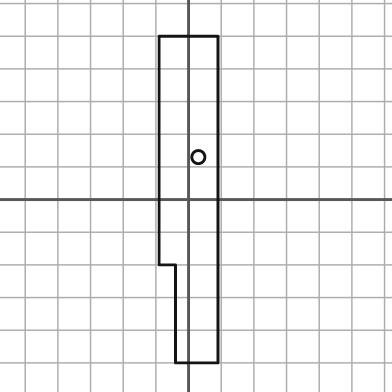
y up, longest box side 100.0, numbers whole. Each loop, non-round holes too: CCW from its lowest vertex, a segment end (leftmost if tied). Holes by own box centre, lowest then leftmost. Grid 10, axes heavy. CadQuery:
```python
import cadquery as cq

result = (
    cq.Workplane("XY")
    .moveTo(-4.0, -50.0)
    .lineTo(9.0, -50.0)
    .lineTo(9.0, 50.0)
    .lineTo(-9.0, 50.0)
    .lineTo(-9.0, -20.0)
    .lineTo(-4.0, -20.0)
    .close()
    .moveTo(3.0, 13.0)
    .circle(2.0)
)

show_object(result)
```